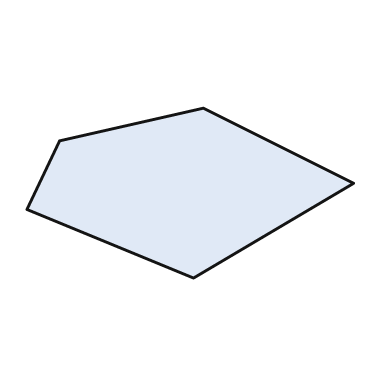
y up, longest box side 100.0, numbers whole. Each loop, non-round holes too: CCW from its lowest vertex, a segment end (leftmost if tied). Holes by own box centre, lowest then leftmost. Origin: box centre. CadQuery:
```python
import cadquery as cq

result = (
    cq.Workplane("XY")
    .moveTo(1.0, -26.0)
    .lineTo(50.0, 3.0)
    .lineTo(4.0, 26.0)
    .lineTo(-40.0, 16.0)
    .lineTo(-50.0, -5.0)
    .close()
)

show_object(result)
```